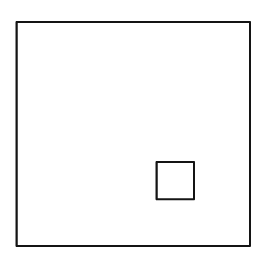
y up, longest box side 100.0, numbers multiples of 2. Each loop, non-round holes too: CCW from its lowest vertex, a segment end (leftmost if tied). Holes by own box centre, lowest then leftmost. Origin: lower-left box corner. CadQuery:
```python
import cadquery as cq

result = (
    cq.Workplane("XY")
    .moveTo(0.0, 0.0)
    .lineTo(100.0, 0.0)
    .lineTo(100.0, 96.0)
    .lineTo(0.0, 96.0)
    .close()
    .moveTo(60.0, 20.0)
    .lineTo(76.0, 20.0)
    .lineTo(76.0, 36.0)
    .lineTo(60.0, 36.0)
    .close()
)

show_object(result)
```